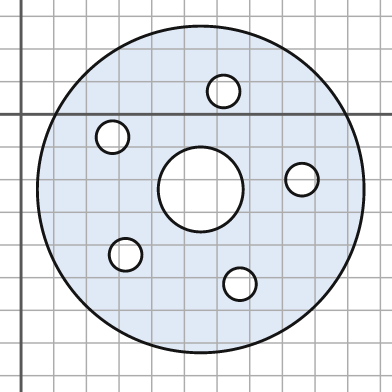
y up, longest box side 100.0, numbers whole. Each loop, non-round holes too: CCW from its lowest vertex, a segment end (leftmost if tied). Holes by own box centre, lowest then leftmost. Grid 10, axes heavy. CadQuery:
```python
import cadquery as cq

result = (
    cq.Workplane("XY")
    .moveTo(55.0, -23.0)
    .circle(50.0)
    .moveTo(67.0, -52.0)
    .circle(5.0)
    .moveTo(32.0, -43.0)
    .circle(5.0)
    .moveTo(55.0, -23.0)
    .circle(13.0)
    .moveTo(86.0, -20.0)
    .circle(5.0)
    .moveTo(28.0, -7.0)
    .circle(5.0)
    .moveTo(62.0, 7.0)
    .circle(5.0)
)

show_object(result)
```